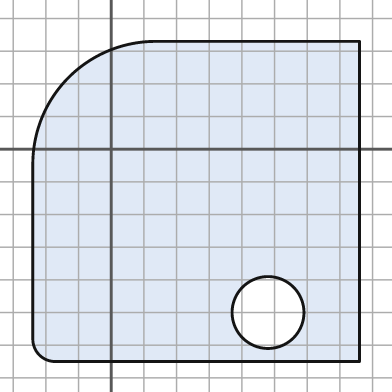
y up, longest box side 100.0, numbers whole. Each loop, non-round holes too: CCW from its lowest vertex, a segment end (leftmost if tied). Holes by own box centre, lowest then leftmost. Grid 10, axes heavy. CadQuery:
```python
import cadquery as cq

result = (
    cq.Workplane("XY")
    .moveTo(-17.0, -65.0)
    .lineTo(76.0, -65.0)
    .lineTo(76.0, 33.0)
    .lineTo(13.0, 33.0)
    .threePointArc((-13.0, 22.0), (-24.0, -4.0))
    .lineTo(-24.0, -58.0)
    .threePointArc((-22.0, -63.0), (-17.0, -65.0))
    .close()
    .moveTo(48.0, -50.0)
    .circle(11.0)
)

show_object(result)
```